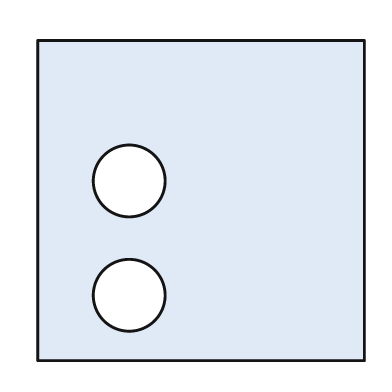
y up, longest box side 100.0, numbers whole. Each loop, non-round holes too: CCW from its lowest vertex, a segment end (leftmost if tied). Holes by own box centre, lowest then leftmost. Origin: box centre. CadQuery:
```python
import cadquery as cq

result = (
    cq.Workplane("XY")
    .moveTo(-50.0, -49.0)
    .lineTo(50.0, -49.0)
    .lineTo(50.0, 49.0)
    .lineTo(-50.0, 49.0)
    .close()
    .moveTo(-22.0, -29.0)
    .circle(11.0)
    .moveTo(-22.0, 6.0)
    .circle(11.0)
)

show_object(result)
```